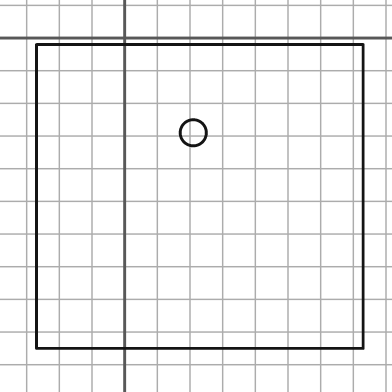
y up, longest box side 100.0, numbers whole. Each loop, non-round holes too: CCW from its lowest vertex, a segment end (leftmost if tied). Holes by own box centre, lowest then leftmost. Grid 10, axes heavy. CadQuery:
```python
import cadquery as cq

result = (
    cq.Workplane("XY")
    .moveTo(-27.0, -95.0)
    .lineTo(73.0, -95.0)
    .lineTo(73.0, -2.0)
    .lineTo(-27.0, -2.0)
    .close()
    .moveTo(21.0, -29.0)
    .circle(4.0)
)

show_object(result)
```